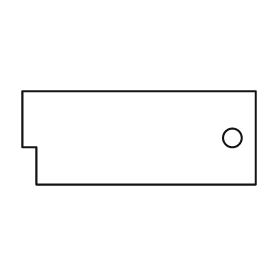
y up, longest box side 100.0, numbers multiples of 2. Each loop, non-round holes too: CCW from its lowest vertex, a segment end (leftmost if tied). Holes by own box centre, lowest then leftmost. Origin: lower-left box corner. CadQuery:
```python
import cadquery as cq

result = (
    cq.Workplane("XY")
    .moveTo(6.0, 0.0)
    .lineTo(100.0, 0.0)
    .lineTo(100.0, 40.0)
    .lineTo(0.0, 40.0)
    .lineTo(0.0, 16.0)
    .lineTo(6.0, 16.0)
    .close()
    .moveTo(90.0, 20.0)
    .circle(4.0)
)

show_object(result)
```